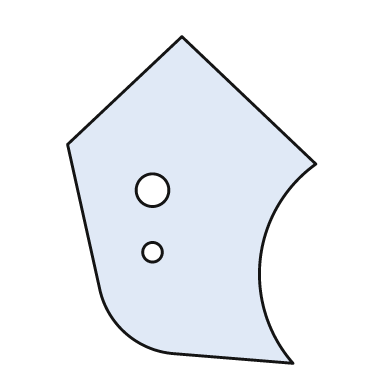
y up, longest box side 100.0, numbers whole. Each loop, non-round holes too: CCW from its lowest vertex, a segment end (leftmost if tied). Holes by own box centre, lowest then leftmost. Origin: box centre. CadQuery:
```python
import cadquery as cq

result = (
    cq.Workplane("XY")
    .moveTo(31.0, -50.0)
    .threePointArc((21.0, -18.0), (38.0, 11.0))
    .lineTo(-3.0, 50.0)
    .lineTo(-38.0, 17.0)
    .lineTo(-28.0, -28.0)
    .threePointArc((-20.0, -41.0), (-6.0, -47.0))
    .close()
    .moveTo(-12.0, -16.0)
    .circle(3.0)
    .moveTo(-12.0, 3.0)
    .circle(5.0)
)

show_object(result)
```